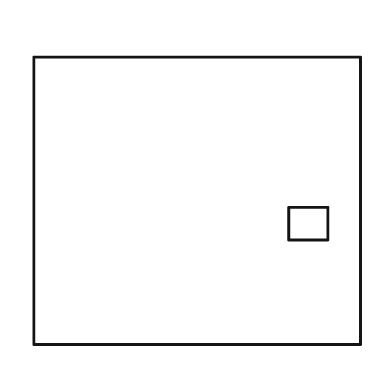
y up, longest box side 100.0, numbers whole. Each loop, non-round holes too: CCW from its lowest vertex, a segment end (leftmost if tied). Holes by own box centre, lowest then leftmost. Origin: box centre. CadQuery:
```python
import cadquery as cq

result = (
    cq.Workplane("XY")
    .moveTo(-50.0, -44.0)
    .lineTo(50.0, -44.0)
    .lineTo(50.0, 44.0)
    .lineTo(-50.0, 44.0)
    .close()
    .moveTo(28.0, -12.0)
    .lineTo(40.0, -12.0)
    .lineTo(40.0, -2.0)
    .lineTo(28.0, -2.0)
    .close()
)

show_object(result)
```